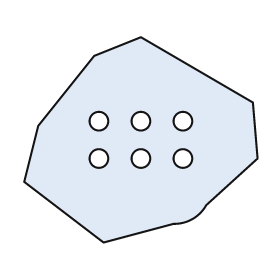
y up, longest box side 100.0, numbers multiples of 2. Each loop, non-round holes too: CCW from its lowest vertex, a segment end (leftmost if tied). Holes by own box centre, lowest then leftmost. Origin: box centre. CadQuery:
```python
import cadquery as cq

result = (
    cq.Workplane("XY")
    .moveTo(-16.0, -44.0)
    .lineTo(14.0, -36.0)
    .threePointArc((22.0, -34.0), (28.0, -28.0))
    .lineTo(50.0, -8.0)
    .lineTo(48.0, 16.0)
    .lineTo(0.0, 44.0)
    .lineTo(-20.0, 36.0)
    .lineTo(-44.0, 6.0)
    .lineTo(-50.0, -18.0)
    .close()
    .moveTo(-18.0, -8.0)
    .circle(4.0)
    .moveTo(0.0, -8.0)
    .circle(4.0)
    .moveTo(18.0, -8.0)
    .circle(4.0)
    .moveTo(-18.0, 8.0)
    .circle(4.0)
    .moveTo(0.0, 8.0)
    .circle(4.0)
    .moveTo(18.0, 8.0)
    .circle(4.0)
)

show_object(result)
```